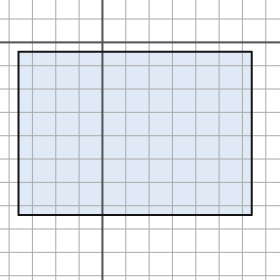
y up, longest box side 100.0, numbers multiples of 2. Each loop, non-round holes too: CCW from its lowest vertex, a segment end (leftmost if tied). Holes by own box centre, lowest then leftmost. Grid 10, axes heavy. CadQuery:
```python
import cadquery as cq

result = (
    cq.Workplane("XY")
    .moveTo(-36.0, -74.0)
    .lineTo(64.0, -74.0)
    .lineTo(64.0, -4.0)
    .lineTo(-36.0, -4.0)
    .close()
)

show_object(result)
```